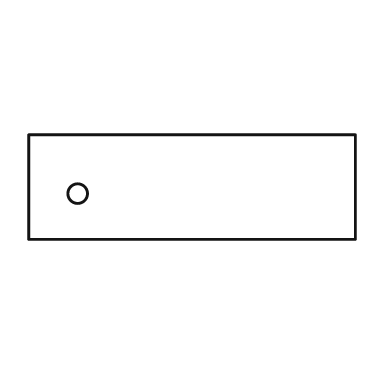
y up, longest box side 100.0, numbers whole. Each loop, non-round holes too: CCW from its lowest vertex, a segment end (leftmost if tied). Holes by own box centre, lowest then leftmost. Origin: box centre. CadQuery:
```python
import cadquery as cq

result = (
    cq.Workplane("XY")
    .moveTo(-50.0, -16.0)
    .lineTo(50.0, -16.0)
    .lineTo(50.0, 16.0)
    .lineTo(-50.0, 16.0)
    .close()
    .moveTo(-35.0, -2.0)
    .circle(3.0)
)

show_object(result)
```